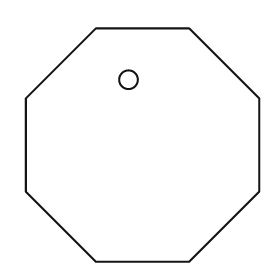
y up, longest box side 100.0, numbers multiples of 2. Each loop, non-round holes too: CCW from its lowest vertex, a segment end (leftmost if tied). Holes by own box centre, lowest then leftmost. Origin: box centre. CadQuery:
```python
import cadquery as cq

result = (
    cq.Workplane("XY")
    .moveTo(-20.0, -50.0)
    .lineTo(20.0, -50.0)
    .lineTo(50.0, -20.0)
    .lineTo(50.0, 20.0)
    .lineTo(20.0, 50.0)
    .lineTo(-20.0, 50.0)
    .lineTo(-50.0, 20.0)
    .lineTo(-50.0, -20.0)
    .close()
    .moveTo(-6.0, 28.0)
    .circle(4.0)
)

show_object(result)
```